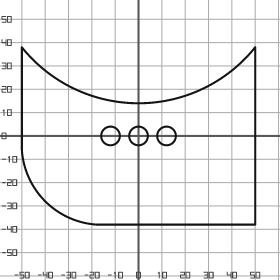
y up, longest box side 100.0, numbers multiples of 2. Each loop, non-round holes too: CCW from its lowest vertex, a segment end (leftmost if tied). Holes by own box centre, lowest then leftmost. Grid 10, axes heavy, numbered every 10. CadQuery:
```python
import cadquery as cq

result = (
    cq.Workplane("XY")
    .moveTo(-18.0, -38.0)
    .lineTo(50.0, -38.0)
    .lineTo(50.0, 38.0)
    .threePointArc((0.0, 14.0), (-50.0, 38.0))
    .lineTo(-50.0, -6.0)
    .threePointArc((-40.0, -28.0), (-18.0, -38.0))
    .close()
    .moveTo(-12.0, 0.0)
    .circle(4.0)
    .moveTo(0.0, 0.0)
    .circle(4.0)
    .moveTo(12.0, 0.0)
    .circle(4.0)
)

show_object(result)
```